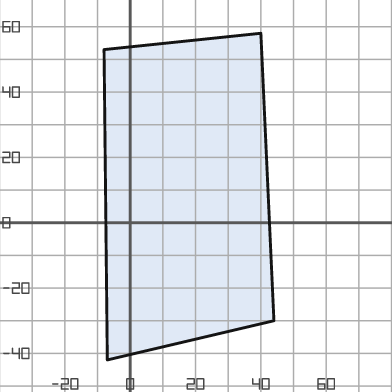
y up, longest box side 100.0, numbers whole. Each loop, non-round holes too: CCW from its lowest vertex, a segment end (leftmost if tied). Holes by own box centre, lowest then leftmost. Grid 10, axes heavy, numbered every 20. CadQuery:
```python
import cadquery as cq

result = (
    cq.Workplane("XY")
    .moveTo(-7.0, -42.0)
    .lineTo(44.0, -30.0)
    .lineTo(40.0, 58.0)
    .lineTo(-8.0, 53.0)
    .close()
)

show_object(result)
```